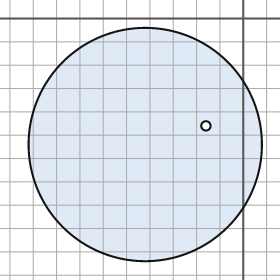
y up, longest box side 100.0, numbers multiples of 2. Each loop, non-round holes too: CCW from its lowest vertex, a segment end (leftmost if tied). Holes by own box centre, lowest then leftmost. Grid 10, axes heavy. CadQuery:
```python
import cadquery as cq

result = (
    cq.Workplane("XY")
    .moveTo(-42.0, -54.0)
    .circle(50.0)
    .moveTo(-16.0, -46.0)
    .circle(2.0)
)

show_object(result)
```